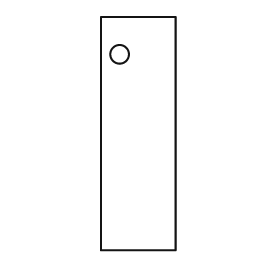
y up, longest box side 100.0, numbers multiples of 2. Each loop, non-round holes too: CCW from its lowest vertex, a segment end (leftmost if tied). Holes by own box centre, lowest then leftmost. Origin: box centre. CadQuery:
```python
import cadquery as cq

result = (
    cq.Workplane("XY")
    .moveTo(-16.0, -50.0)
    .lineTo(16.0, -50.0)
    .lineTo(16.0, 50.0)
    .lineTo(-16.0, 50.0)
    .close()
    .moveTo(-8.0, 34.0)
    .circle(4.0)
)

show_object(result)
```